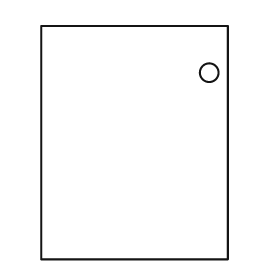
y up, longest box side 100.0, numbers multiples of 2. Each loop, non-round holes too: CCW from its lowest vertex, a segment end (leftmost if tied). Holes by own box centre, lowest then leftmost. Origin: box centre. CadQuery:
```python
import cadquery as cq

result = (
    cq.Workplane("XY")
    .moveTo(-40.0, -50.0)
    .lineTo(40.0, -50.0)
    .lineTo(40.0, 50.0)
    .lineTo(-40.0, 50.0)
    .close()
    .moveTo(32.0, 30.0)
    .circle(4.0)
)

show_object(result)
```